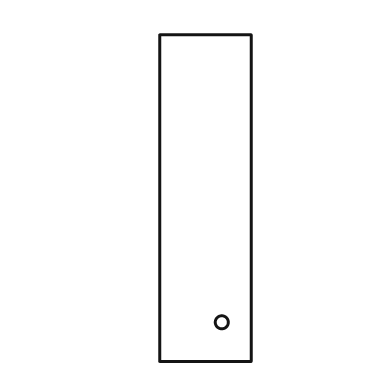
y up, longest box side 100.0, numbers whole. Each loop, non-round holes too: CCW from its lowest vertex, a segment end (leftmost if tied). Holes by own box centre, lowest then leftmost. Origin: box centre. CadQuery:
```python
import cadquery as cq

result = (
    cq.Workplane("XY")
    .moveTo(-14.0, -50.0)
    .lineTo(14.0, -50.0)
    .lineTo(14.0, 50.0)
    .lineTo(-14.0, 50.0)
    .close()
    .moveTo(5.0, -38.0)
    .circle(2.0)
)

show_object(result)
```